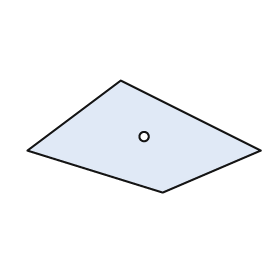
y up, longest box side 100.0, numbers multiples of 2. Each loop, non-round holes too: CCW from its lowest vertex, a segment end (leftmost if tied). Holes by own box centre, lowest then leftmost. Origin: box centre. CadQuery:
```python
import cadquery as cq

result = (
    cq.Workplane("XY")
    .moveTo(8.0, -24.0)
    .lineTo(50.0, -6.0)
    .lineTo(-10.0, 24.0)
    .lineTo(-50.0, -6.0)
    .close()
    .moveTo(0.0, 0.0)
    .circle(2.0)
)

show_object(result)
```